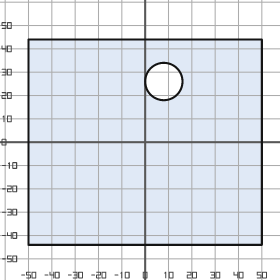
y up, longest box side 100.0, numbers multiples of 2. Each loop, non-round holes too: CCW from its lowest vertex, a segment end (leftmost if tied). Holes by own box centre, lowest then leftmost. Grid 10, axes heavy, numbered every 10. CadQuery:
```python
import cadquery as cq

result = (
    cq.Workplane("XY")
    .moveTo(-50.0, -44.0)
    .lineTo(50.0, -44.0)
    .lineTo(50.0, 44.0)
    .lineTo(-50.0, 44.0)
    .close()
    .moveTo(8.0, 26.0)
    .circle(8.0)
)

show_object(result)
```